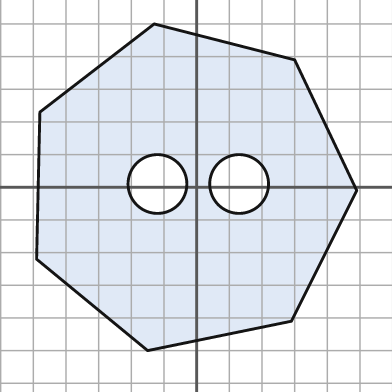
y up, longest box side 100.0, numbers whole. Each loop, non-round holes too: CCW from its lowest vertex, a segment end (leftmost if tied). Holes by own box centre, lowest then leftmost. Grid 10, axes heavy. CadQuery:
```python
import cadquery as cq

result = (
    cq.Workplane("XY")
    .moveTo(-15.0, -50.0)
    .lineTo(29.0, -41.0)
    .lineTo(49.0, -1.0)
    .lineTo(30.0, 39.0)
    .lineTo(-13.0, 50.0)
    .lineTo(-48.0, 23.0)
    .lineTo(-49.0, -22.0)
    .close()
    .moveTo(-12.0, 1.0)
    .circle(9.0)
    .moveTo(13.0, 1.0)
    .circle(9.0)
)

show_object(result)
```